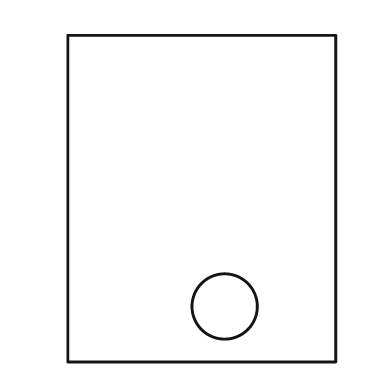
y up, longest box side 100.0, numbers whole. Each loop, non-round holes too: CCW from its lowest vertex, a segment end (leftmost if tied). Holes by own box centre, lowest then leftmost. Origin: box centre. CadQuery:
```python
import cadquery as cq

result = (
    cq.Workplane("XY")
    .moveTo(-41.0, -50.0)
    .lineTo(41.0, -50.0)
    .lineTo(41.0, 50.0)
    .lineTo(-41.0, 50.0)
    .close()
    .moveTo(7.0, -33.0)
    .circle(10.0)
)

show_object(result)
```